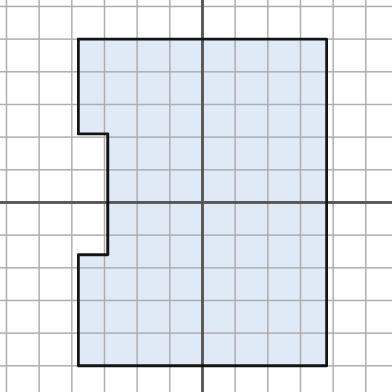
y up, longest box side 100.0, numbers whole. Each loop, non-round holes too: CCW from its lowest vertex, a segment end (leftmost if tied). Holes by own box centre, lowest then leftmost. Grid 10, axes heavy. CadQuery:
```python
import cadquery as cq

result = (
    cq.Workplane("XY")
    .moveTo(-38.0, -50.0)
    .lineTo(38.0, -50.0)
    .lineTo(38.0, 50.0)
    .lineTo(-38.0, 50.0)
    .lineTo(-38.0, 21.0)
    .lineTo(-29.0, 21.0)
    .lineTo(-29.0, -16.0)
    .lineTo(-38.0, -16.0)
    .close()
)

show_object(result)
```